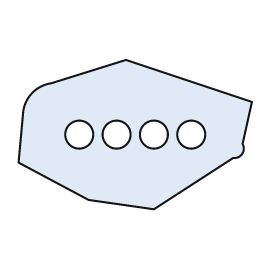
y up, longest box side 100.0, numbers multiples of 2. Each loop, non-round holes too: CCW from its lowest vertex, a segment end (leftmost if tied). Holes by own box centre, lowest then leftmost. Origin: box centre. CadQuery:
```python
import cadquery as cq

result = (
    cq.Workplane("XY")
    .moveTo(8.0, -32.0)
    .lineTo(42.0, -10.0)
    .threePointArc((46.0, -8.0), (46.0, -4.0))
    .lineTo(50.0, 14.0)
    .lineTo(-4.0, 32.0)
    .lineTo(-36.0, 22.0)
    .threePointArc((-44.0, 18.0), (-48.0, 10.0))
    .lineTo(-50.0, -12.0)
    .lineTo(-20.0, -28.0)
    .close()
    .moveTo(-24.0, 0.0)
    .circle(6.0)
    .moveTo(-8.0, 0.0)
    .circle(6.0)
    .moveTo(8.0, 0.0)
    .circle(6.0)
    .moveTo(24.0, 0.0)
    .circle(6.0)
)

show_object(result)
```